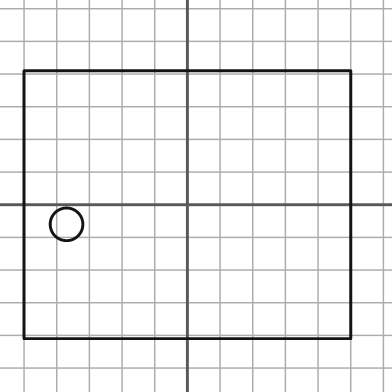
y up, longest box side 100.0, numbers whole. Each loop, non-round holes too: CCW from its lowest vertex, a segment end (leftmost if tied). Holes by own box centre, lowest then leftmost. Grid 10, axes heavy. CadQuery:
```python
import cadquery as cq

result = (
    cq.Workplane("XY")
    .moveTo(-50.0, -41.0)
    .lineTo(50.0, -41.0)
    .lineTo(50.0, 41.0)
    .lineTo(-50.0, 41.0)
    .close()
    .moveTo(-37.0, -6.0)
    .circle(5.0)
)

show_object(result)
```